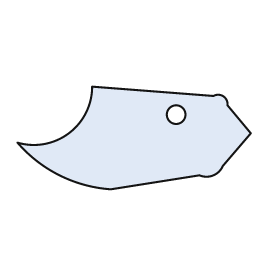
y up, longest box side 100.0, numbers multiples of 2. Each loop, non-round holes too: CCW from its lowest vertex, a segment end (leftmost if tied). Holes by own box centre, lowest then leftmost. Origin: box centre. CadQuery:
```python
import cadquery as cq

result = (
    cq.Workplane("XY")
    .moveTo(-10.0, -22.0)
    .lineTo(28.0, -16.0)
    .threePointArc((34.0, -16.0), (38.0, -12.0))
    .lineTo(50.0, 2.0)
    .lineTo(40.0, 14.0)
    .threePointArc((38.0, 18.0), (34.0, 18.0))
    .lineTo(-18.0, 22.0)
    .threePointArc((-28.0, 2.0), (-50.0, -2.0))
    .threePointArc((-32.0, -16.0), (-10.0, -22.0))
    .close()
    .moveTo(18.0, 10.0)
    .circle(4.0)
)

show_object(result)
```